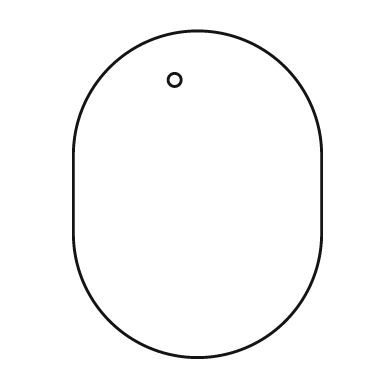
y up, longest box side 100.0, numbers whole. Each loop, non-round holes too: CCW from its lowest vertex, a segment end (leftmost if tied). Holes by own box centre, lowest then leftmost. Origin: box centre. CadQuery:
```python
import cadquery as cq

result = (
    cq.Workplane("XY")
    .moveTo(-38.0, -12.0)
    .threePointArc((0.0, -50.0), (38.0, -12.0))
    .lineTo(38.0, 12.0)
    .threePointArc((0.0, 50.0), (-38.0, 12.0))
    .close()
    .moveTo(-7.0, 35.0)
    .circle(2.0)
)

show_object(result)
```